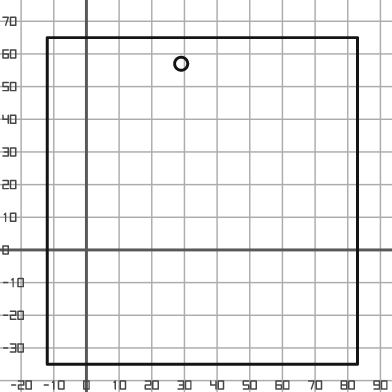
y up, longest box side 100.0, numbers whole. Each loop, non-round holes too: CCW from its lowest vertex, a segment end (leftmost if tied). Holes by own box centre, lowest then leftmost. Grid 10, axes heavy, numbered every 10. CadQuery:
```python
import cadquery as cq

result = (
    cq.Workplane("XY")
    .moveTo(-12.0, -35.0)
    .lineTo(83.0, -35.0)
    .lineTo(83.0, 65.0)
    .lineTo(-12.0, 65.0)
    .close()
    .moveTo(29.0, 57.0)
    .circle(2.0)
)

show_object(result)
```